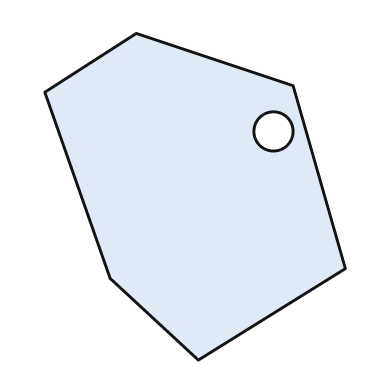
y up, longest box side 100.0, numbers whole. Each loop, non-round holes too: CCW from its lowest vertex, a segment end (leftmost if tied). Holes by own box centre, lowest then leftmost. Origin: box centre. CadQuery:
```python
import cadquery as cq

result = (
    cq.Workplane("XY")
    .moveTo(1.0, -50.0)
    .lineTo(46.0, -22.0)
    .lineTo(30.0, 34.0)
    .lineTo(-18.0, 50.0)
    .lineTo(-46.0, 32.0)
    .lineTo(-26.0, -25.0)
    .close()
    .moveTo(24.0, 20.0)
    .circle(6.0)
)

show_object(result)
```